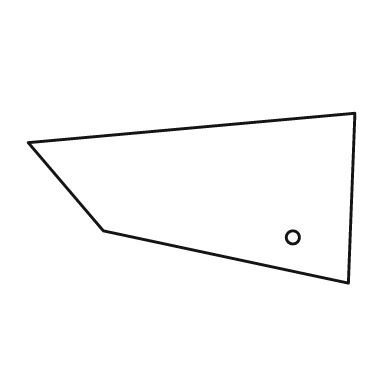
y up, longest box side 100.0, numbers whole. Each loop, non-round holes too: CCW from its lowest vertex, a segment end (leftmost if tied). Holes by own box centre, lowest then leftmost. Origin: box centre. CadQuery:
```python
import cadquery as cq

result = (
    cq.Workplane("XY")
    .moveTo(48.0, -26.0)
    .lineTo(50.0, 26.0)
    .lineTo(-50.0, 17.0)
    .lineTo(-27.0, -10.0)
    .close()
    .moveTo(31.0, -12.0)
    .circle(2.0)
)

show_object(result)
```